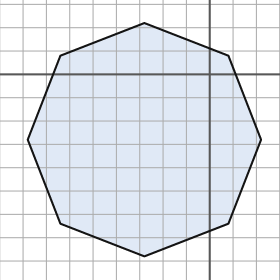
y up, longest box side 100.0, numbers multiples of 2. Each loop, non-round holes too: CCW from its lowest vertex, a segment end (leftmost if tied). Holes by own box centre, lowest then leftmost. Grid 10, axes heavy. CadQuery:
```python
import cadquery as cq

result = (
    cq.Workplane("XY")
    .moveTo(-28.0, -78.0)
    .lineTo(8.0, -64.0)
    .lineTo(22.0, -28.0)
    .lineTo(8.0, 8.0)
    .lineTo(-28.0, 22.0)
    .lineTo(-64.0, 8.0)
    .lineTo(-78.0, -28.0)
    .lineTo(-64.0, -64.0)
    .close()
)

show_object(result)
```